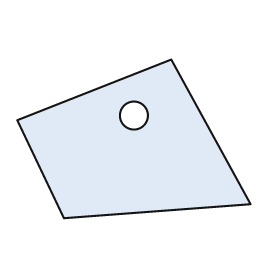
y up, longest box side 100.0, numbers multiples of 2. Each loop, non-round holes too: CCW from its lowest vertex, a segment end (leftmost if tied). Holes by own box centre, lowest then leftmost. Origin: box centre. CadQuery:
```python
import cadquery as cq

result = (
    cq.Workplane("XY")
    .moveTo(-30.0, -34.0)
    .lineTo(50.0, -28.0)
    .lineTo(16.0, 34.0)
    .lineTo(-50.0, 8.0)
    .close()
    .moveTo(0.0, 10.0)
    .circle(6.0)
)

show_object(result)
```